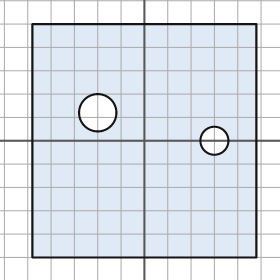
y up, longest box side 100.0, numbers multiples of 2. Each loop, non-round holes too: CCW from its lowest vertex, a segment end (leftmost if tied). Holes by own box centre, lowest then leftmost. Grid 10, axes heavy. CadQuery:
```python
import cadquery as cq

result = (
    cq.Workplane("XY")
    .moveTo(-48.0, -50.0)
    .lineTo(48.0, -50.0)
    .lineTo(48.0, 50.0)
    .lineTo(-48.0, 50.0)
    .close()
    .moveTo(30.0, 0.0)
    .circle(6.0)
    .moveTo(-20.0, 12.0)
    .circle(8.0)
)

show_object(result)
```